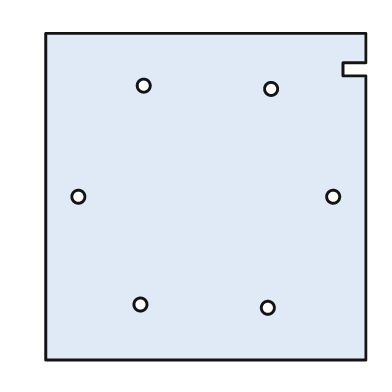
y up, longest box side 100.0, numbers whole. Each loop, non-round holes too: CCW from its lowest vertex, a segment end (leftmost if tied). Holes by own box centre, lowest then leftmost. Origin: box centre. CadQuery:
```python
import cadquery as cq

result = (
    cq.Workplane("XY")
    .moveTo(-49.0, -50.0)
    .lineTo(49.0, -50.0)
    .lineTo(49.0, 37.0)
    .lineTo(42.0, 37.0)
    .lineTo(42.0, 41.0)
    .lineTo(49.0, 41.0)
    .lineTo(49.0, 50.0)
    .lineTo(-49.0, 50.0)
    .close()
    .moveTo(19.0, -34.0)
    .circle(2.0)
    .moveTo(-20.0, -33.0)
    .circle(2.0)
    .moveTo(-39.0, 0.0)
    .circle(2.0)
    .moveTo(39.0, 0.0)
    .circle(2.0)
    .moveTo(20.0, 33.0)
    .circle(2.0)
    .moveTo(-19.0, 34.0)
    .circle(2.0)
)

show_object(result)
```